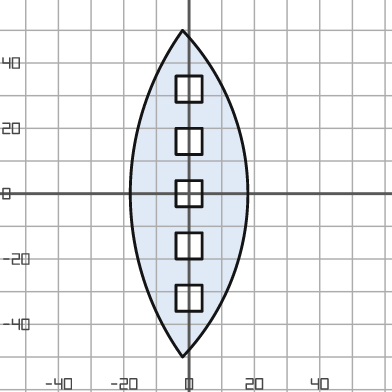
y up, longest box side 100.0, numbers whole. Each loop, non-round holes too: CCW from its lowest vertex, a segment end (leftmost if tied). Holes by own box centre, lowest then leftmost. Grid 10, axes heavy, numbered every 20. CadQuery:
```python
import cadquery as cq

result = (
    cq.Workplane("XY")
    .moveTo(-2.0, -50.0)
    .threePointArc((18.0, 0.0), (-2.0, 50.0))
    .threePointArc((-18.0, 0.0), (-2.0, -50.0))
    .close()
    .moveTo(-4.0, -36.0)
    .lineTo(4.0, -36.0)
    .lineTo(4.0, -28.0)
    .lineTo(-4.0, -28.0)
    .close()
    .moveTo(-4.0, -20.0)
    .lineTo(4.0, -20.0)
    .lineTo(4.0, -12.0)
    .lineTo(-4.0, -12.0)
    .close()
    .moveTo(-4.0, -4.0)
    .lineTo(4.0, -4.0)
    .lineTo(4.0, 4.0)
    .lineTo(-4.0, 4.0)
    .close()
    .moveTo(-4.0, 12.0)
    .lineTo(4.0, 12.0)
    .lineTo(4.0, 20.0)
    .lineTo(-4.0, 20.0)
    .close()
    .moveTo(-4.0, 28.0)
    .lineTo(4.0, 28.0)
    .lineTo(4.0, 36.0)
    .lineTo(-4.0, 36.0)
    .close()
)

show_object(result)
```